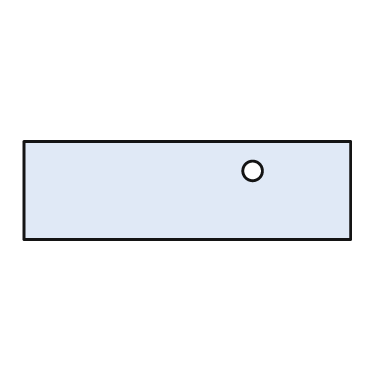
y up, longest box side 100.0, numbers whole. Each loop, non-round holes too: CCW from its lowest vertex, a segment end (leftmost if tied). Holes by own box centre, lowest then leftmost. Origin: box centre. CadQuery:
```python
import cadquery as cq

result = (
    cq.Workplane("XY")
    .moveTo(-50.0, -15.0)
    .lineTo(50.0, -15.0)
    .lineTo(50.0, 15.0)
    .lineTo(-50.0, 15.0)
    .close()
    .moveTo(20.0, 6.0)
    .circle(3.0)
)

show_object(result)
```